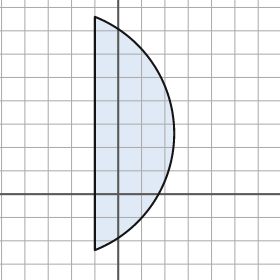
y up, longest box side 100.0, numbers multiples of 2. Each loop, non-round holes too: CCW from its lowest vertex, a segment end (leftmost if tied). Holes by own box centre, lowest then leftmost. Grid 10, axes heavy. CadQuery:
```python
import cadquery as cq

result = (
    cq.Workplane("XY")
    .moveTo(-10.0, -24.0)
    .threePointArc((24.0, 26.0), (-10.0, 76.0))
    .close()
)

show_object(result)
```